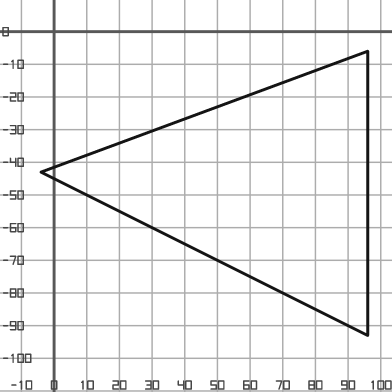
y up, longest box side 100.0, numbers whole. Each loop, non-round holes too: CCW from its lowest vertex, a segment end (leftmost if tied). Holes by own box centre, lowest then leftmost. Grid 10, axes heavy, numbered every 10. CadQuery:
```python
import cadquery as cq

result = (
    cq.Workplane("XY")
    .moveTo(96.0, -93.0)
    .lineTo(96.0, -6.0)
    .lineTo(-4.0, -43.0)
    .close()
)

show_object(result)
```